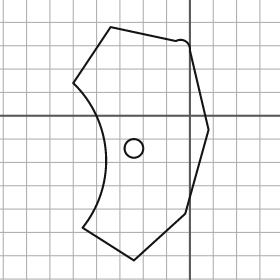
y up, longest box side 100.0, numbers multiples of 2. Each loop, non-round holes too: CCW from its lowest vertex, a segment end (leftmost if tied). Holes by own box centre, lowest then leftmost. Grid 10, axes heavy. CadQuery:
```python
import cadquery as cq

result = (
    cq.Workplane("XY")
    .moveTo(-24.0, -62.0)
    .lineTo(-2.0, -42.0)
    .lineTo(8.0, -6.0)
    .lineTo(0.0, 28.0)
    .threePointArc((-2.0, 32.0), (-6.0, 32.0))
    .lineTo(-34.0, 38.0)
    .lineTo(-50.0, 14.0)
    .threePointArc((-36.0, -16.0), (-46.0, -48.0))
    .close()
    .moveTo(-24.0, -14.0)
    .circle(4.0)
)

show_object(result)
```